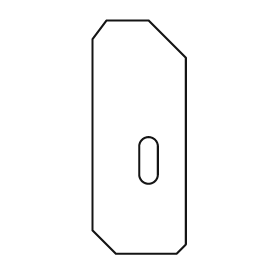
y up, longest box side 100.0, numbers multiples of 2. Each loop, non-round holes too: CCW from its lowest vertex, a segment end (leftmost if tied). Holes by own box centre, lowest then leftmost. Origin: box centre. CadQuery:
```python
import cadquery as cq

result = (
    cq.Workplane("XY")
    .moveTo(-10.0, -50.0)
    .lineTo(16.0, -50.0)
    .lineTo(20.0, -46.0)
    .lineTo(20.0, 34.0)
    .lineTo(4.0, 50.0)
    .lineTo(-14.0, 50.0)
    .lineTo(-20.0, 42.0)
    .lineTo(-20.0, -40.0)
    .close()
    .moveTo(0.0, -16.0)
    .threePointArc((4.0, -20.0), (8.0, -16.0))
    .lineTo(8.0, -4.0)
    .threePointArc((4.0, 0.0), (0.0, -4.0))
    .close()
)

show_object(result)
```